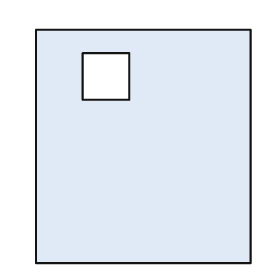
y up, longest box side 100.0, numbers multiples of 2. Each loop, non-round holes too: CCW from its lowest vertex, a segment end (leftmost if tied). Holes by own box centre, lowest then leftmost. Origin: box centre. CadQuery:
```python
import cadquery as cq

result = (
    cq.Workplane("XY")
    .moveTo(-46.0, -50.0)
    .lineTo(46.0, -50.0)
    .lineTo(46.0, 50.0)
    .lineTo(-46.0, 50.0)
    .close()
    .moveTo(-26.0, 20.0)
    .lineTo(-6.0, 20.0)
    .lineTo(-6.0, 40.0)
    .lineTo(-26.0, 40.0)
    .close()
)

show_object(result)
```